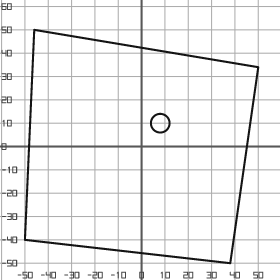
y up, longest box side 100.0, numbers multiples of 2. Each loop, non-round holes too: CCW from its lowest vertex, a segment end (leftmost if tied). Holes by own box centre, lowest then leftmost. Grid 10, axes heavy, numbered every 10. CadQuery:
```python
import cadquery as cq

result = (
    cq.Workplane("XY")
    .moveTo(38.0, -50.0)
    .lineTo(50.0, 34.0)
    .lineTo(-46.0, 50.0)
    .lineTo(-50.0, -40.0)
    .close()
    .moveTo(8.0, 10.0)
    .circle(4.0)
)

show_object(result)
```